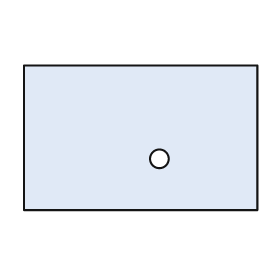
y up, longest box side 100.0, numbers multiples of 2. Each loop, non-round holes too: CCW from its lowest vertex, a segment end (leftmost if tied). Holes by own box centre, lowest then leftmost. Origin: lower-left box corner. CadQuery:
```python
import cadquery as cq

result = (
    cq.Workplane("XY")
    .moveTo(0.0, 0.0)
    .lineTo(100.0, 0.0)
    .lineTo(100.0, 62.0)
    .lineTo(0.0, 62.0)
    .close()
    .moveTo(58.0, 22.0)
    .circle(4.0)
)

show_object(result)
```